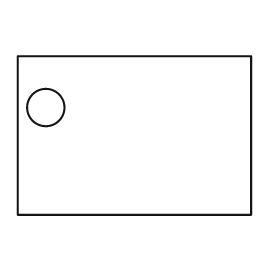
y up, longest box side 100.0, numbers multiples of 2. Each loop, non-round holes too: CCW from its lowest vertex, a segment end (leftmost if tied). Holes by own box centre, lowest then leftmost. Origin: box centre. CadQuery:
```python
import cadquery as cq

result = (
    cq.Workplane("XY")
    .moveTo(-50.0, -34.0)
    .lineTo(50.0, -34.0)
    .lineTo(50.0, 34.0)
    .lineTo(-50.0, 34.0)
    .close()
    .moveTo(-38.0, 12.0)
    .circle(8.0)
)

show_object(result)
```